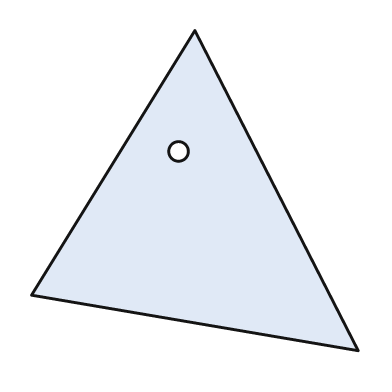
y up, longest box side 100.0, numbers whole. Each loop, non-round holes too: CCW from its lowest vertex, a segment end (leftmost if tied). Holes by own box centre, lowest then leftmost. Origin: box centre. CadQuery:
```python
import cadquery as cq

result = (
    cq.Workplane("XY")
    .moveTo(50.0, -49.0)
    .lineTo(0.0, 49.0)
    .lineTo(-50.0, -32.0)
    .close()
    .moveTo(-5.0, 12.0)
    .circle(3.0)
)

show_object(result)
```